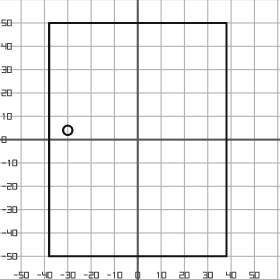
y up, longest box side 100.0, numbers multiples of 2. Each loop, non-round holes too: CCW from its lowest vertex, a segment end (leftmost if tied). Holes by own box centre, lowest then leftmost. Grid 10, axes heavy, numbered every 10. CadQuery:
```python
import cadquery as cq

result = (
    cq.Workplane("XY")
    .moveTo(-38.0, -50.0)
    .lineTo(38.0, -50.0)
    .lineTo(38.0, 50.0)
    .lineTo(-38.0, 50.0)
    .close()
    .moveTo(-30.0, 4.0)
    .circle(2.0)
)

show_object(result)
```